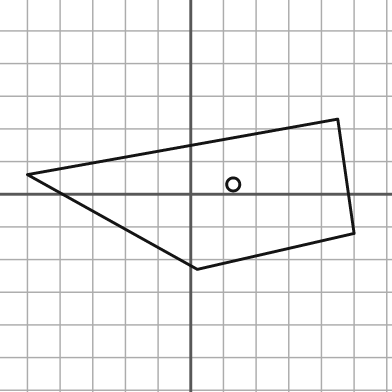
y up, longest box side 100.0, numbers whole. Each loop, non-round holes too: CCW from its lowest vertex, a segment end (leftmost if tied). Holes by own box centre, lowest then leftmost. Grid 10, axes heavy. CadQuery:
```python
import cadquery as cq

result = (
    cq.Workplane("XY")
    .moveTo(2.0, -23.0)
    .lineTo(50.0, -12.0)
    .lineTo(45.0, 23.0)
    .lineTo(-50.0, 6.0)
    .close()
    .moveTo(13.0, 3.0)
    .circle(2.0)
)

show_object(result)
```